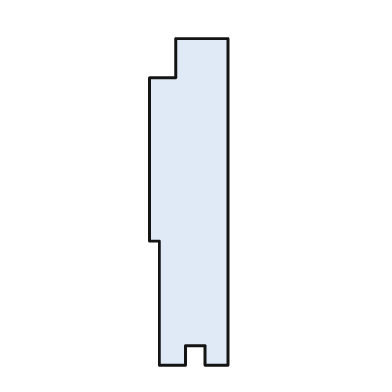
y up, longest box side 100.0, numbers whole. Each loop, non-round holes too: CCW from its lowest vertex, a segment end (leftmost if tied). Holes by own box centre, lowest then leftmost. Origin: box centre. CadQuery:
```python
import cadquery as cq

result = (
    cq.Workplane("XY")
    .moveTo(-9.0, -50.0)
    .lineTo(-1.0, -50.0)
    .lineTo(-1.0, -44.0)
    .lineTo(5.0, -44.0)
    .lineTo(5.0, -50.0)
    .lineTo(12.0, -50.0)
    .lineTo(12.0, 50.0)
    .lineTo(-4.0, 50.0)
    .lineTo(-4.0, 38.0)
    .lineTo(-12.0, 38.0)
    .lineTo(-12.0, -12.0)
    .lineTo(-9.0, -12.0)
    .close()
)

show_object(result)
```